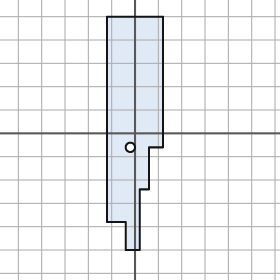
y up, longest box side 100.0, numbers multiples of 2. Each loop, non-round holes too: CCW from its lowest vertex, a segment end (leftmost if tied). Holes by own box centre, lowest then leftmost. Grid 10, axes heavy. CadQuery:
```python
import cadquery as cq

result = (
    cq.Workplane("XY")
    .moveTo(-4.0, -50.0)
    .lineTo(2.0, -50.0)
    .lineTo(2.0, -24.0)
    .lineTo(6.0, -24.0)
    .lineTo(6.0, -6.0)
    .lineTo(12.0, -6.0)
    .lineTo(12.0, 50.0)
    .lineTo(-12.0, 50.0)
    .lineTo(-12.0, -38.0)
    .lineTo(-4.0, -38.0)
    .close()
    .moveTo(-2.0, -6.0)
    .circle(2.0)
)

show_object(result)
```